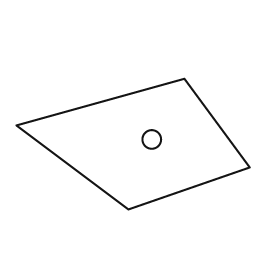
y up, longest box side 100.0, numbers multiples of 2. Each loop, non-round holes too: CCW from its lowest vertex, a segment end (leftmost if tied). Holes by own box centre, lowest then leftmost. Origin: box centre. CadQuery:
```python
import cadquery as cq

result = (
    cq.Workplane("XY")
    .moveTo(-2.0, -28.0)
    .lineTo(50.0, -10.0)
    .lineTo(22.0, 28.0)
    .lineTo(-50.0, 8.0)
    .close()
    .moveTo(8.0, 2.0)
    .circle(4.0)
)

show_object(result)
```